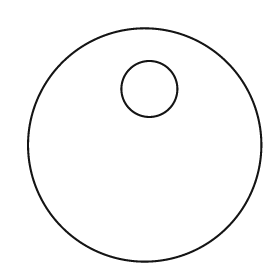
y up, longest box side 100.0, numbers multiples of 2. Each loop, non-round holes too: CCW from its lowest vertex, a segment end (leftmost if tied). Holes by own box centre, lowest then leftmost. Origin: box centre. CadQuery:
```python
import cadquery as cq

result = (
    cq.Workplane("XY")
    .moveTo(0.0, 0.0)
    .circle(50.0)
    .moveTo(2.0, 24.0)
    .circle(12.0)
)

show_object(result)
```